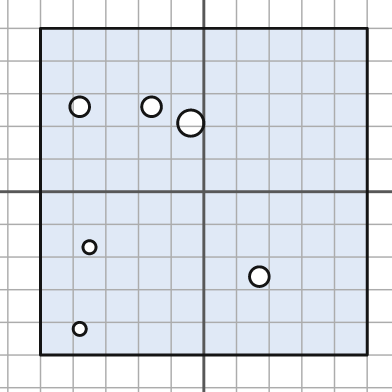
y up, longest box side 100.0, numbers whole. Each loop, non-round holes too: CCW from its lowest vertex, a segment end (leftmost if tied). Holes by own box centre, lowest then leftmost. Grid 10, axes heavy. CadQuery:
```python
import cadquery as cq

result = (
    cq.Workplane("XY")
    .moveTo(-50.0, -50.0)
    .lineTo(50.0, -50.0)
    .lineTo(50.0, 50.0)
    .lineTo(-50.0, 50.0)
    .close()
    .moveTo(-38.0, -42.0)
    .circle(2.0)
    .moveTo(17.0, -26.0)
    .circle(3.0)
    .moveTo(-35.0, -17.0)
    .circle(2.0)
    .moveTo(-4.0, 21.0)
    .circle(4.0)
    .moveTo(-38.0, 26.0)
    .circle(3.0)
    .moveTo(-16.0, 26.0)
    .circle(3.0)
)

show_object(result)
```